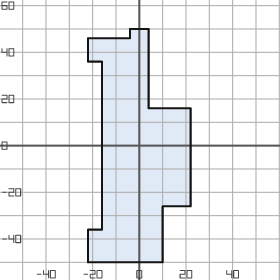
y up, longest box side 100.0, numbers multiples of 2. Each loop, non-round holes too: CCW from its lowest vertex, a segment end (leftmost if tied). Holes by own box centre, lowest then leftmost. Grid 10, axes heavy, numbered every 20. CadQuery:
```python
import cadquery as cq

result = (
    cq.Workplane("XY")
    .moveTo(-22.0, -50.0)
    .lineTo(10.0, -50.0)
    .lineTo(10.0, -26.0)
    .lineTo(22.0, -26.0)
    .lineTo(22.0, 16.0)
    .lineTo(4.0, 16.0)
    .lineTo(4.0, 50.0)
    .lineTo(-4.0, 50.0)
    .lineTo(-4.0, 46.0)
    .lineTo(-22.0, 46.0)
    .lineTo(-22.0, 36.0)
    .lineTo(-16.0, 36.0)
    .lineTo(-16.0, -36.0)
    .lineTo(-22.0, -36.0)
    .close()
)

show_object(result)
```